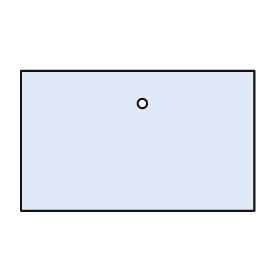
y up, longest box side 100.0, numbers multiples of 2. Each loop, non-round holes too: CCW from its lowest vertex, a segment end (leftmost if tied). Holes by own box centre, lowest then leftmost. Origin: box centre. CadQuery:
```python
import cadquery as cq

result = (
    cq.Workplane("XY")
    .moveTo(-50.0, -30.0)
    .lineTo(50.0, -30.0)
    .lineTo(50.0, 30.0)
    .lineTo(-50.0, 30.0)
    .close()
    .moveTo(2.0, 16.0)
    .circle(2.0)
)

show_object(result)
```